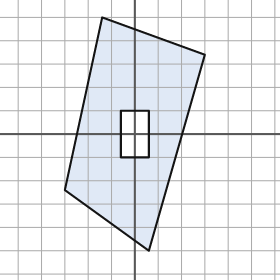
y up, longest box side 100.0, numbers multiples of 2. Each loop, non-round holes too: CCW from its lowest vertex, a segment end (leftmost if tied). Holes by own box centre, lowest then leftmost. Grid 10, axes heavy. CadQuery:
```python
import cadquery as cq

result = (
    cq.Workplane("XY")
    .moveTo(6.0, -50.0)
    .lineTo(30.0, 34.0)
    .lineTo(-14.0, 50.0)
    .lineTo(-30.0, -24.0)
    .close()
    .moveTo(-6.0, -10.0)
    .lineTo(6.0, -10.0)
    .lineTo(6.0, 10.0)
    .lineTo(-6.0, 10.0)
    .close()
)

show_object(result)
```